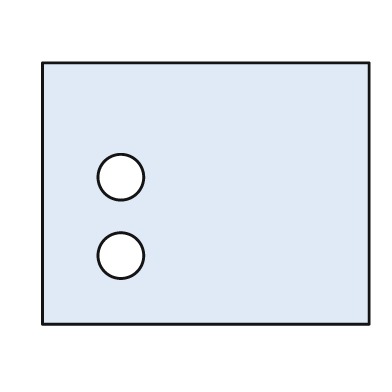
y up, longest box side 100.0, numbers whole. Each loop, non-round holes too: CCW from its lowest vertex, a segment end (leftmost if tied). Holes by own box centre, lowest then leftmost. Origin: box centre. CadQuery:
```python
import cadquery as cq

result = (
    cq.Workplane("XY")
    .moveTo(-50.0, -40.0)
    .lineTo(50.0, -40.0)
    .lineTo(50.0, 40.0)
    .lineTo(-50.0, 40.0)
    .close()
    .moveTo(-26.0, -19.0)
    .circle(7.0)
    .moveTo(-26.0, 5.0)
    .circle(7.0)
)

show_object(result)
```